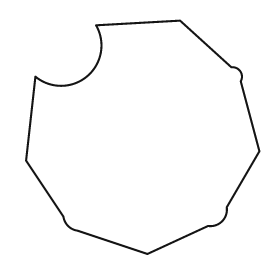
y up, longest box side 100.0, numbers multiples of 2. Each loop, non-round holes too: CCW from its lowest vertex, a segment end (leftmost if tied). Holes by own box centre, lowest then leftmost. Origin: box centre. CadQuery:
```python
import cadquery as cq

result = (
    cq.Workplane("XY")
    .moveTo(2.0, -50.0)
    .lineTo(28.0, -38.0)
    .threePointArc((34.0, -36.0), (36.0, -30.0))
    .lineTo(50.0, -6.0)
    .lineTo(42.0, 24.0)
    .threePointArc((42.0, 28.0), (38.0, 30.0))
    .lineTo(16.0, 50.0)
    .lineTo(-20.0, 48.0)
    .threePointArc((-24.0, 26.0), (-46.0, 26.0))
    .lineTo(-50.0, -10.0)
    .lineTo(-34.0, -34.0)
    .threePointArc((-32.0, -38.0), (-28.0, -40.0))
    .close()
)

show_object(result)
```